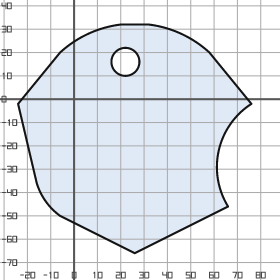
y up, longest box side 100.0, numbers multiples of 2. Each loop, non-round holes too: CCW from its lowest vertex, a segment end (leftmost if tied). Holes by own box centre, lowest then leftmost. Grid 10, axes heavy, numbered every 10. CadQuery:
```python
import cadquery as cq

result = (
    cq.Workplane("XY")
    .moveTo(26.0, -66.0)
    .lineTo(66.0, -46.0)
    .threePointArc((62.0, -22.0), (76.0, -2.0))
    .lineTo(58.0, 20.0)
    .threePointArc((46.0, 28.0), (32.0, 32.0))
    .lineTo(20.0, 32.0)
    .threePointArc((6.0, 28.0), (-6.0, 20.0))
    .lineTo(-24.0, -2.0)
    .lineTo(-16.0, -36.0)
    .threePointArc((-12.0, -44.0), (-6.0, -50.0))
    .close()
    .moveTo(22.0, 16.0)
    .circle(6.0)
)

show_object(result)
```